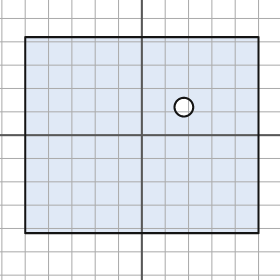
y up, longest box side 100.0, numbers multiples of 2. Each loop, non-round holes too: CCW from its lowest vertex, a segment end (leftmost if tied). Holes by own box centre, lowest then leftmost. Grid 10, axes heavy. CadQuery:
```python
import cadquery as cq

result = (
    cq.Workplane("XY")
    .moveTo(-50.0, -42.0)
    .lineTo(50.0, -42.0)
    .lineTo(50.0, 42.0)
    .lineTo(-50.0, 42.0)
    .close()
    .moveTo(18.0, 12.0)
    .circle(4.0)
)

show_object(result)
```